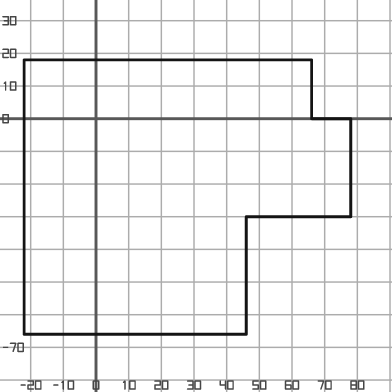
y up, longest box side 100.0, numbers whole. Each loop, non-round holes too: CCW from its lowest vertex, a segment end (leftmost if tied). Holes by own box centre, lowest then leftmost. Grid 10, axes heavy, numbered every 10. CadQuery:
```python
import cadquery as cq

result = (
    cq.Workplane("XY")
    .moveTo(-22.0, -66.0)
    .lineTo(46.0, -66.0)
    .lineTo(46.0, -30.0)
    .lineTo(78.0, -30.0)
    .lineTo(78.0, 0.0)
    .lineTo(66.0, 0.0)
    .lineTo(66.0, 18.0)
    .lineTo(-22.0, 18.0)
    .close()
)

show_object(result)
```